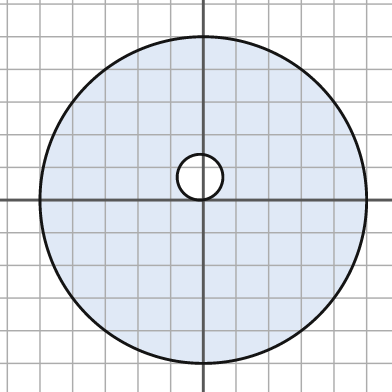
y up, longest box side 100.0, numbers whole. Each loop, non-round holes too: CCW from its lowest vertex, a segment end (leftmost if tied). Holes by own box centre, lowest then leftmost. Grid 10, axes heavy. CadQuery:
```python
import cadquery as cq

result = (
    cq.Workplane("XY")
    .moveTo(0.0, 0.0)
    .circle(50.0)
    .moveTo(-1.0, 7.0)
    .circle(7.0)
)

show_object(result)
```